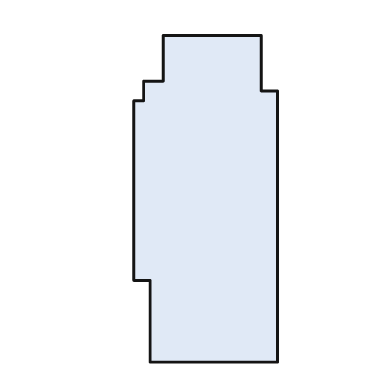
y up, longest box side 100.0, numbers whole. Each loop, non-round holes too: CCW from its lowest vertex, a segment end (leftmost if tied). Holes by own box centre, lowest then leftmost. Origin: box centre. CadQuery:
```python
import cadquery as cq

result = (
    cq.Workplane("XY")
    .moveTo(-17.0, -50.0)
    .lineTo(22.0, -50.0)
    .lineTo(22.0, 33.0)
    .lineTo(17.0, 33.0)
    .lineTo(17.0, 50.0)
    .lineTo(-13.0, 50.0)
    .lineTo(-13.0, 36.0)
    .lineTo(-19.0, 36.0)
    .lineTo(-19.0, 30.0)
    .lineTo(-22.0, 30.0)
    .lineTo(-22.0, -25.0)
    .lineTo(-17.0, -25.0)
    .close()
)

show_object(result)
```